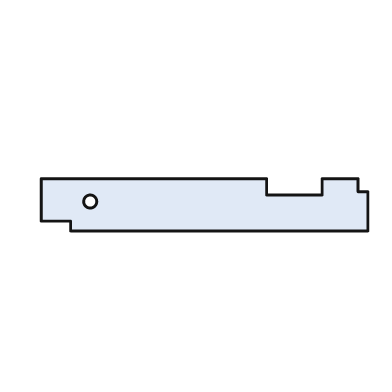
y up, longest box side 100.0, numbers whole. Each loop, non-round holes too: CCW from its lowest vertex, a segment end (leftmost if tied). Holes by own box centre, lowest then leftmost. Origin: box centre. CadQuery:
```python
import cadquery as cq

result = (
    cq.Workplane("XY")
    .moveTo(-41.0, -8.0)
    .lineTo(50.0, -8.0)
    .lineTo(50.0, 4.0)
    .lineTo(47.0, 4.0)
    .lineTo(47.0, 8.0)
    .lineTo(36.0, 8.0)
    .lineTo(36.0, 3.0)
    .lineTo(19.0, 3.0)
    .lineTo(19.0, 8.0)
    .lineTo(-50.0, 8.0)
    .lineTo(-50.0, -5.0)
    .lineTo(-41.0, -5.0)
    .close()
    .moveTo(-35.0, 1.0)
    .circle(2.0)
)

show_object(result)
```